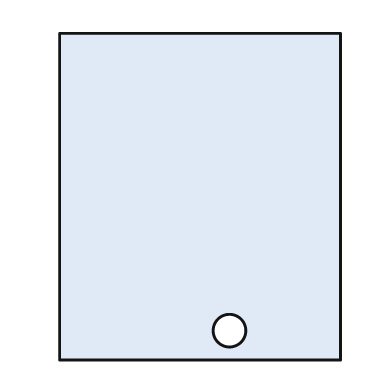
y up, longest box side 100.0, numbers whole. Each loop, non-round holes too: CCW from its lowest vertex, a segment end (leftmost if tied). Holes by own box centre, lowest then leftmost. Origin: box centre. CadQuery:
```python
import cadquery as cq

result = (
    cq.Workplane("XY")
    .moveTo(-43.0, -50.0)
    .lineTo(43.0, -50.0)
    .lineTo(43.0, 50.0)
    .lineTo(-43.0, 50.0)
    .close()
    .moveTo(9.0, -41.0)
    .circle(5.0)
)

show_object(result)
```